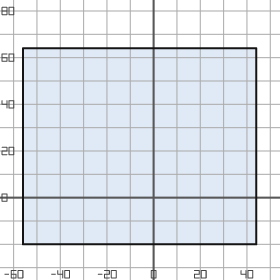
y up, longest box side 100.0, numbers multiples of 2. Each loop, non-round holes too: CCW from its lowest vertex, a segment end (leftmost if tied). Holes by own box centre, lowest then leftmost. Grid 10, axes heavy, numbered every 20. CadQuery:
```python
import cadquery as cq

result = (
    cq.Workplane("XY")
    .moveTo(-56.0, -20.0)
    .lineTo(44.0, -20.0)
    .lineTo(44.0, 64.0)
    .lineTo(-56.0, 64.0)
    .close()
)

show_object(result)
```